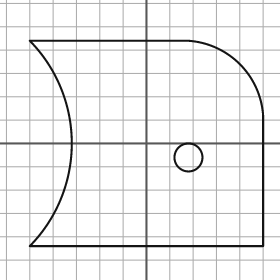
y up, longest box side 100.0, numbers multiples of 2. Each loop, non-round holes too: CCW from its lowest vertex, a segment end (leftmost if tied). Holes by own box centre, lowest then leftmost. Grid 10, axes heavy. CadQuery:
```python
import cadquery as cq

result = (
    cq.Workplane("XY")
    .moveTo(-50.0, -44.0)
    .lineTo(50.0, -44.0)
    .lineTo(50.0, 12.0)
    .threePointArc((40.0, 34.0), (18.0, 44.0))
    .lineTo(-50.0, 44.0)
    .threePointArc((-32.0, 0.0), (-50.0, -44.0))
    .close()
    .moveTo(18.0, -6.0)
    .circle(6.0)
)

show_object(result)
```